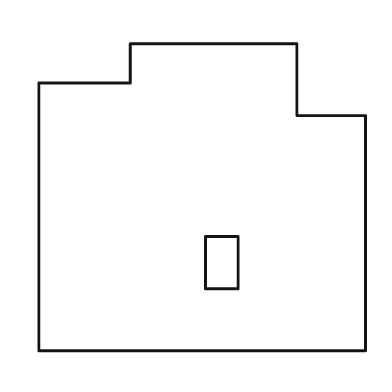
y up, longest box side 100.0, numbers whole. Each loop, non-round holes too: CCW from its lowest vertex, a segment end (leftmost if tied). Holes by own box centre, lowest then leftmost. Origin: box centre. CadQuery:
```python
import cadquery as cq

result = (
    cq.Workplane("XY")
    .moveTo(-50.0, -47.0)
    .lineTo(50.0, -47.0)
    .lineTo(50.0, 25.0)
    .lineTo(29.0, 25.0)
    .lineTo(29.0, 47.0)
    .lineTo(-22.0, 47.0)
    .lineTo(-22.0, 35.0)
    .lineTo(-50.0, 35.0)
    .close()
    .moveTo(1.0, -28.0)
    .lineTo(11.0, -28.0)
    .lineTo(11.0, -12.0)
    .lineTo(1.0, -12.0)
    .close()
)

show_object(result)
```